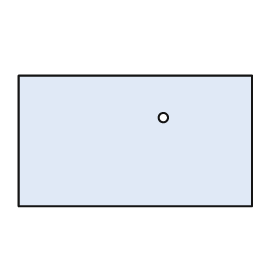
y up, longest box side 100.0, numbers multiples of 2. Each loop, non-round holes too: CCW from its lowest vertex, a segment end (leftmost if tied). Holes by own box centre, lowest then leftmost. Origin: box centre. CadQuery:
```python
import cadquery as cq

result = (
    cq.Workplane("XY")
    .moveTo(-50.0, -28.0)
    .lineTo(50.0, -28.0)
    .lineTo(50.0, 28.0)
    .lineTo(-50.0, 28.0)
    .close()
    .moveTo(12.0, 10.0)
    .circle(2.0)
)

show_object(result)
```